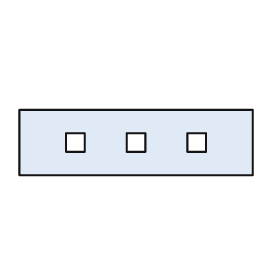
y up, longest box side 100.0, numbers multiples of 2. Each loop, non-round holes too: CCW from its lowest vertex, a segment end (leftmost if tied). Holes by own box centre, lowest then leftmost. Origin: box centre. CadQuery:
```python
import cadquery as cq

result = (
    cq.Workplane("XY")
    .moveTo(-50.0, -14.0)
    .lineTo(50.0, -14.0)
    .lineTo(50.0, 14.0)
    .lineTo(-50.0, 14.0)
    .close()
    .moveTo(-30.0, -4.0)
    .lineTo(-22.0, -4.0)
    .lineTo(-22.0, 4.0)
    .lineTo(-30.0, 4.0)
    .close()
    .moveTo(-4.0, -4.0)
    .lineTo(4.0, -4.0)
    .lineTo(4.0, 4.0)
    .lineTo(-4.0, 4.0)
    .close()
    .moveTo(22.0, -4.0)
    .lineTo(30.0, -4.0)
    .lineTo(30.0, 4.0)
    .lineTo(22.0, 4.0)
    .close()
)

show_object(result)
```